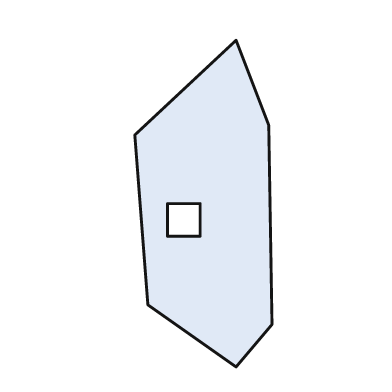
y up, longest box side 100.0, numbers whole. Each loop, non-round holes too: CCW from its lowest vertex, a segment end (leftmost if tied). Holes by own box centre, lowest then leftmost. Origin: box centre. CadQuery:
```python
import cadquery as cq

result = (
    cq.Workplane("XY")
    .moveTo(10.0, -50.0)
    .lineTo(21.0, -37.0)
    .lineTo(20.0, 24.0)
    .lineTo(10.0, 50.0)
    .lineTo(-21.0, 21.0)
    .lineTo(-17.0, -31.0)
    .close()
    .moveTo(-11.0, -10.0)
    .lineTo(-1.0, -10.0)
    .lineTo(-1.0, 0.0)
    .lineTo(-11.0, 0.0)
    .close()
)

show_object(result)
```